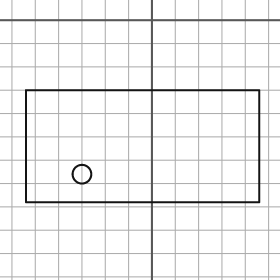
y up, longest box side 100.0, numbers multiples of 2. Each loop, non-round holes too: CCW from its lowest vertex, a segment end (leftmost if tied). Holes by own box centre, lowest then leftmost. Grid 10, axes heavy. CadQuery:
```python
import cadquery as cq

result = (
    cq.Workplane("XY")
    .moveTo(-54.0, -78.0)
    .lineTo(46.0, -78.0)
    .lineTo(46.0, -30.0)
    .lineTo(-54.0, -30.0)
    .close()
    .moveTo(-30.0, -66.0)
    .circle(4.0)
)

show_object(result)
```